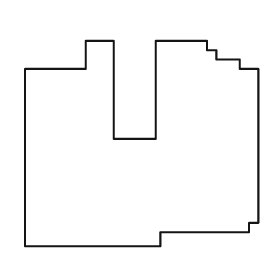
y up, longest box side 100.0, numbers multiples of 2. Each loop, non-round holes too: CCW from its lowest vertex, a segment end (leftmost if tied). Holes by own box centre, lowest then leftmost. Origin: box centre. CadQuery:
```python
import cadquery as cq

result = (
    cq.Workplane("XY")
    .moveTo(-50.0, -44.0)
    .lineTo(8.0, -44.0)
    .lineTo(8.0, -38.0)
    .lineTo(46.0, -38.0)
    .lineTo(46.0, -34.0)
    .lineTo(50.0, -34.0)
    .lineTo(50.0, 32.0)
    .lineTo(42.0, 32.0)
    .lineTo(42.0, 36.0)
    .lineTo(32.0, 36.0)
    .lineTo(32.0, 40.0)
    .lineTo(28.0, 40.0)
    .lineTo(28.0, 44.0)
    .lineTo(6.0, 44.0)
    .lineTo(6.0, 2.0)
    .lineTo(-12.0, 2.0)
    .lineTo(-12.0, 44.0)
    .lineTo(-24.0, 44.0)
    .lineTo(-24.0, 32.0)
    .lineTo(-50.0, 32.0)
    .close()
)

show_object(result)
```